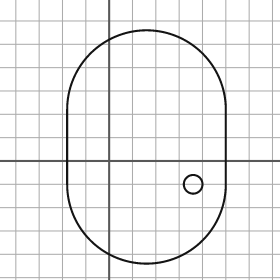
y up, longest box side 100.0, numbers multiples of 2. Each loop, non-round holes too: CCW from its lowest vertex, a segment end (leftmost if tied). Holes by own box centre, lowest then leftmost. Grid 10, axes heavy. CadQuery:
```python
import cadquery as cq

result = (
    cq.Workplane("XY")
    .moveTo(-18.0, -10.0)
    .threePointArc((16.0, -44.0), (50.0, -10.0))
    .lineTo(50.0, 22.0)
    .threePointArc((16.0, 56.0), (-18.0, 22.0))
    .close()
    .moveTo(36.0, -10.0)
    .circle(4.0)
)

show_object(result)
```